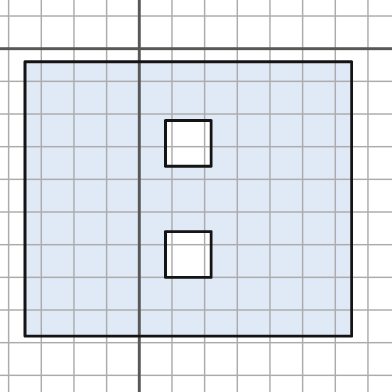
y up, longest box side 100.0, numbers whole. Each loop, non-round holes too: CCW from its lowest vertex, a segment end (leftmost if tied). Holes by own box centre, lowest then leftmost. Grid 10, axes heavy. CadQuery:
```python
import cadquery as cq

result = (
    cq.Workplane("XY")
    .moveTo(-35.0, -88.0)
    .lineTo(65.0, -88.0)
    .lineTo(65.0, -4.0)
    .lineTo(-35.0, -4.0)
    .close()
    .moveTo(8.0, -70.0)
    .lineTo(22.0, -70.0)
    .lineTo(22.0, -56.0)
    .lineTo(8.0, -56.0)
    .close()
    .moveTo(8.0, -36.0)
    .lineTo(22.0, -36.0)
    .lineTo(22.0, -22.0)
    .lineTo(8.0, -22.0)
    .close()
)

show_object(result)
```